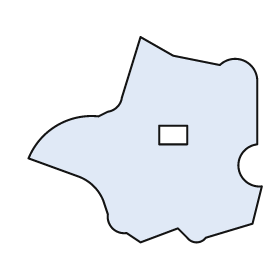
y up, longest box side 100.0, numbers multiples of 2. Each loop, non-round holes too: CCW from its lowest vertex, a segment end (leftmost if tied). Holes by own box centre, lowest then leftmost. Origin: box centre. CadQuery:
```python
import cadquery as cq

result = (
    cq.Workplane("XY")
    .moveTo(-2.0, -44.0)
    .lineTo(14.0, -38.0)
    .lineTo(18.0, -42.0)
    .threePointArc((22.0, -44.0), (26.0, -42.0))
    .lineTo(46.0, -36.0)
    .lineTo(50.0, -20.0)
    .threePointArc((40.0, -12.0), (48.0, -2.0))
    .lineTo(48.0, 26.0)
    .threePointArc((42.0, 34.0), (32.0, 32.0))
    .lineTo(12.0, 36.0)
    .lineTo(-2.0, 44.0)
    .lineTo(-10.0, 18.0)
    .threePointArc((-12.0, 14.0), (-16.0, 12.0))
    .lineTo(-20.0, 10.0)
    .threePointArc((-38.0, 6.0), (-50.0, -8.0))
    .lineTo(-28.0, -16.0)
    .threePointArc((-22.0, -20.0), (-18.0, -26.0))
    .lineTo(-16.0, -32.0)
    .threePointArc((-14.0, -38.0), (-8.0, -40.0))
    .close()
    .moveTo(6.0, -2.0)
    .lineTo(18.0, -2.0)
    .lineTo(18.0, 6.0)
    .lineTo(6.0, 6.0)
    .close()
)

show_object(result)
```